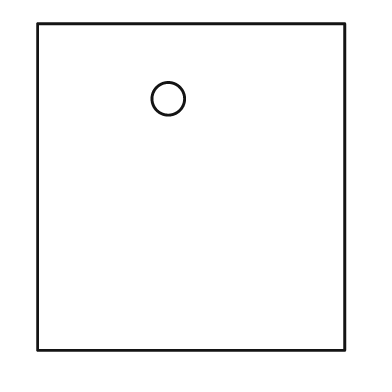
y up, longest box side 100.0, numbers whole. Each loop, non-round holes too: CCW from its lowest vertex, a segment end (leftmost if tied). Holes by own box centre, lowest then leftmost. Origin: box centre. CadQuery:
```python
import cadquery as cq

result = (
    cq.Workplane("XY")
    .moveTo(-47.0, -50.0)
    .lineTo(47.0, -50.0)
    .lineTo(47.0, 50.0)
    .lineTo(-47.0, 50.0)
    .close()
    .moveTo(-7.0, 27.0)
    .circle(5.0)
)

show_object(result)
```